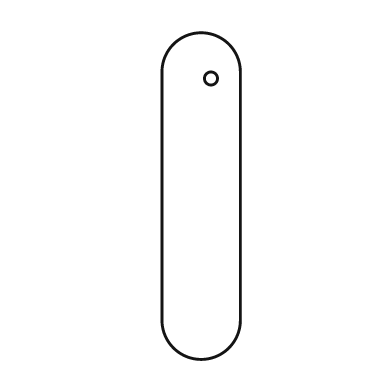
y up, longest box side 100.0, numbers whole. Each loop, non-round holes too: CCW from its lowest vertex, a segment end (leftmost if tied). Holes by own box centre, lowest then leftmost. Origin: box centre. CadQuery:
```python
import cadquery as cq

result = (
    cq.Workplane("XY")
    .moveTo(-12.0, -38.0)
    .threePointArc((0.0, -50.0), (12.0, -38.0))
    .lineTo(12.0, 38.0)
    .threePointArc((0.0, 50.0), (-12.0, 38.0))
    .close()
    .moveTo(3.0, 36.0)
    .circle(2.0)
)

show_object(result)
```